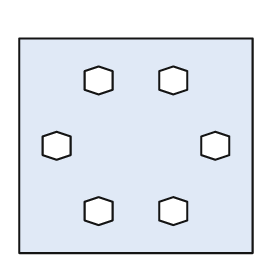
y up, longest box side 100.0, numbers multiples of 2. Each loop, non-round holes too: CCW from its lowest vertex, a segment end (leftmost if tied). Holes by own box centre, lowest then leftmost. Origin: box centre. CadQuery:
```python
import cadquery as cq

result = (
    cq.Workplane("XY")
    .moveTo(-50.0, -46.0)
    .lineTo(50.0, -46.0)
    .lineTo(50.0, 46.0)
    .lineTo(-50.0, 46.0)
    .close()
    .moveTo(-16.0, -34.0)
    .lineTo(-10.0, -32.0)
    .lineTo(-10.0, -24.0)
    .lineTo(-16.0, -22.0)
    .lineTo(-22.0, -24.0)
    .lineTo(-22.0, -32.0)
    .close()
    .moveTo(16.0, -34.0)
    .lineTo(22.0, -32.0)
    .lineTo(22.0, -24.0)
    .lineTo(16.0, -22.0)
    .lineTo(10.0, -24.0)
    .lineTo(10.0, -32.0)
    .close()
    .moveTo(-34.0, -6.0)
    .lineTo(-28.0, -4.0)
    .lineTo(-28.0, 4.0)
    .lineTo(-34.0, 6.0)
    .lineTo(-40.0, 4.0)
    .lineTo(-40.0, -4.0)
    .close()
    .moveTo(34.0, -6.0)
    .lineTo(40.0, -4.0)
    .lineTo(40.0, 4.0)
    .lineTo(34.0, 6.0)
    .lineTo(28.0, 4.0)
    .lineTo(28.0, -4.0)
    .close()
    .moveTo(-16.0, 22.0)
    .lineTo(-10.0, 24.0)
    .lineTo(-10.0, 32.0)
    .lineTo(-16.0, 34.0)
    .lineTo(-22.0, 32.0)
    .lineTo(-22.0, 24.0)
    .close()
    .moveTo(16.0, 22.0)
    .lineTo(22.0, 24.0)
    .lineTo(22.0, 32.0)
    .lineTo(16.0, 34.0)
    .lineTo(10.0, 32.0)
    .lineTo(10.0, 24.0)
    .close()
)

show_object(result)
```